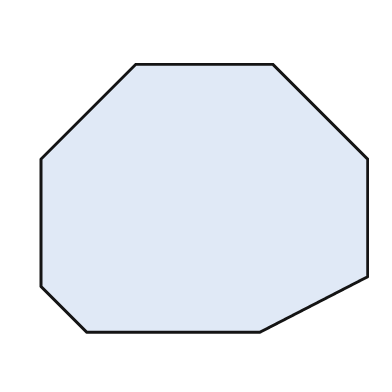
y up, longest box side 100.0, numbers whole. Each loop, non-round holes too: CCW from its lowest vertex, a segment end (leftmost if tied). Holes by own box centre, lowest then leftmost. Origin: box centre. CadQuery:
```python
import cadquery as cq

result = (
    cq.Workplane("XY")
    .moveTo(-36.0, -41.0)
    .lineTo(17.0, -41.0)
    .lineTo(50.0, -24.0)
    .lineTo(50.0, 12.0)
    .lineTo(21.0, 41.0)
    .lineTo(-21.0, 41.0)
    .lineTo(-50.0, 12.0)
    .lineTo(-50.0, -27.0)
    .close()
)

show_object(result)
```